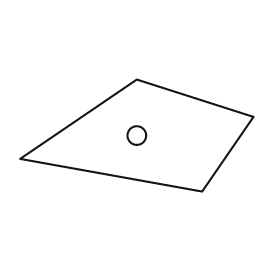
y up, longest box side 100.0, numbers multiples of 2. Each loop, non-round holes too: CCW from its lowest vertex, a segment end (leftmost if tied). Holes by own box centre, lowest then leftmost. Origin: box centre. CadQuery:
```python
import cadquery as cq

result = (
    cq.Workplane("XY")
    .moveTo(28.0, -24.0)
    .lineTo(50.0, 8.0)
    .lineTo(0.0, 24.0)
    .lineTo(-50.0, -10.0)
    .close()
    .moveTo(0.0, 0.0)
    .circle(4.0)
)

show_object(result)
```